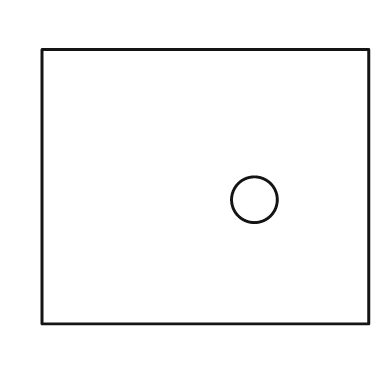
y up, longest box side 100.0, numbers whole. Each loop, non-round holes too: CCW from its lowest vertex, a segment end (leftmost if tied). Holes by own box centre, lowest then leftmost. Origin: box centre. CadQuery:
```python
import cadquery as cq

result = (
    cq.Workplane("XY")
    .moveTo(-50.0, -42.0)
    .lineTo(50.0, -42.0)
    .lineTo(50.0, 42.0)
    .lineTo(-50.0, 42.0)
    .close()
    .moveTo(15.0, -4.0)
    .circle(7.0)
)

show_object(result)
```